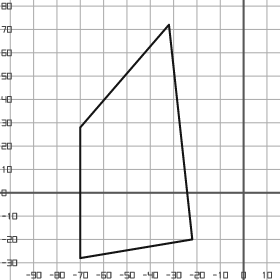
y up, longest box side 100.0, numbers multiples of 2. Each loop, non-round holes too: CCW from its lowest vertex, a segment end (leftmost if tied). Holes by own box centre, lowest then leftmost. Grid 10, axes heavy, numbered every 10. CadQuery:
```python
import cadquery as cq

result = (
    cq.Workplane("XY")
    .moveTo(-70.0, -28.0)
    .lineTo(-22.0, -20.0)
    .lineTo(-32.0, 72.0)
    .lineTo(-70.0, 28.0)
    .close()
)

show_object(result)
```